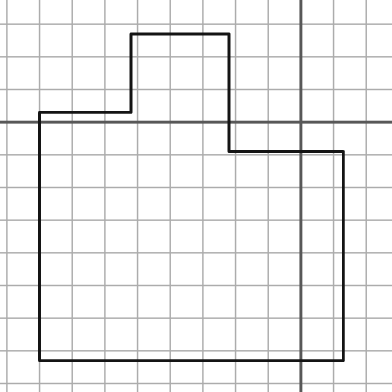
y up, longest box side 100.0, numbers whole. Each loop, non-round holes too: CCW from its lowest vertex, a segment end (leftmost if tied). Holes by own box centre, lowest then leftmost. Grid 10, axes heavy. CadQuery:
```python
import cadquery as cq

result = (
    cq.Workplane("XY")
    .moveTo(-80.0, -73.0)
    .lineTo(13.0, -73.0)
    .lineTo(13.0, -9.0)
    .lineTo(-22.0, -9.0)
    .lineTo(-22.0, 27.0)
    .lineTo(-52.0, 27.0)
    .lineTo(-52.0, 3.0)
    .lineTo(-80.0, 3.0)
    .close()
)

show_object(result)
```